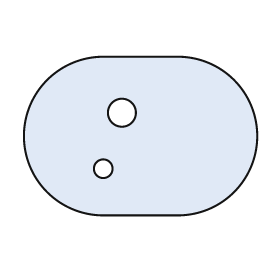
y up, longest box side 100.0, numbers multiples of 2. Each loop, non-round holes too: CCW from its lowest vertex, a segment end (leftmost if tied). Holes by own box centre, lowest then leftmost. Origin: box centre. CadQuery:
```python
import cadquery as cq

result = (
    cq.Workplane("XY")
    .moveTo(-16.0, -34.0)
    .lineTo(16.0, -34.0)
    .threePointArc((50.0, 0.0), (16.0, 34.0))
    .lineTo(-16.0, 34.0)
    .threePointArc((-50.0, 0.0), (-16.0, -34.0))
    .close()
    .moveTo(-16.0, -14.0)
    .circle(4.0)
    .moveTo(-8.0, 10.0)
    .circle(6.0)
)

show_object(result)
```